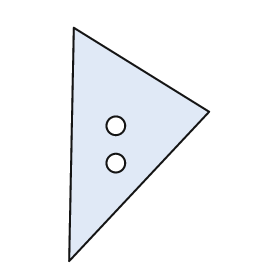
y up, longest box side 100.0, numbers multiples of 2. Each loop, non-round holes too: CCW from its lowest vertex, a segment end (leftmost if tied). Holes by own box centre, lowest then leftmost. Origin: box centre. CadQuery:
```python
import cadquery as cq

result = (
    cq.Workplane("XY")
    .moveTo(-30.0, -50.0)
    .lineTo(30.0, 14.0)
    .lineTo(-28.0, 50.0)
    .close()
    .moveTo(-10.0, -8.0)
    .circle(4.0)
    .moveTo(-10.0, 8.0)
    .circle(4.0)
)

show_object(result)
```